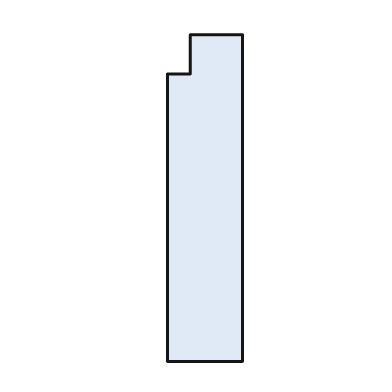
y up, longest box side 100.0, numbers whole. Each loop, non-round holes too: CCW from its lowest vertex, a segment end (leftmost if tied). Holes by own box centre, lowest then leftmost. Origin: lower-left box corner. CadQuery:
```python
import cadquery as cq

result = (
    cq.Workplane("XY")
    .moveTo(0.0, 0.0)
    .lineTo(23.0, 0.0)
    .lineTo(23.0, 100.0)
    .lineTo(7.0, 100.0)
    .lineTo(7.0, 88.0)
    .lineTo(0.0, 88.0)
    .close()
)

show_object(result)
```